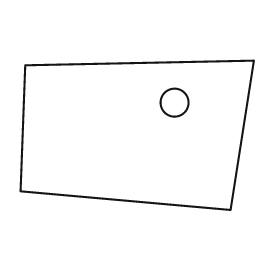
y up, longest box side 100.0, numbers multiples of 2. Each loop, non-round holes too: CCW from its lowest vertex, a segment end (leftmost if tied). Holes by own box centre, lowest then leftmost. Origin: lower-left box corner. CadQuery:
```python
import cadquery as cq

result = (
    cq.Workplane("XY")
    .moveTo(90.0, 0.0)
    .lineTo(100.0, 64.0)
    .lineTo(2.0, 62.0)
    .lineTo(0.0, 8.0)
    .close()
    .moveTo(66.0, 46.0)
    .circle(6.0)
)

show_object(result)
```